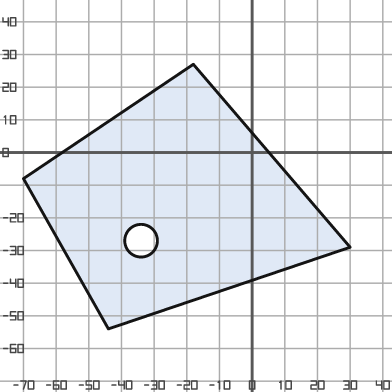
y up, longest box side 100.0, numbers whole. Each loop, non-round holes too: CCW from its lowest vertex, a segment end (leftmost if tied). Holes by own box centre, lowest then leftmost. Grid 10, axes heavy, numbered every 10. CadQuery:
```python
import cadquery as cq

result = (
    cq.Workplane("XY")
    .moveTo(-44.0, -54.0)
    .lineTo(30.0, -29.0)
    .lineTo(-18.0, 27.0)
    .lineTo(-70.0, -8.0)
    .close()
    .moveTo(-34.0, -27.0)
    .circle(5.0)
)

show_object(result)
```